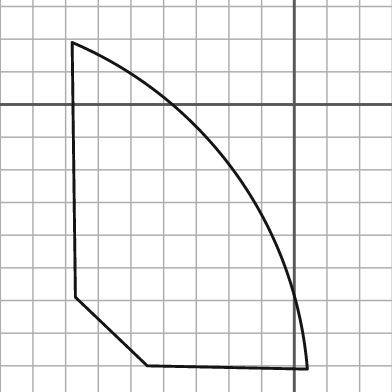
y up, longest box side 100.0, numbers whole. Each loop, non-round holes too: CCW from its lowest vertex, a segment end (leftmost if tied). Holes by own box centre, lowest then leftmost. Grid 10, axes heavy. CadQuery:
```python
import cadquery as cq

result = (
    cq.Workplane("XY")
    .moveTo(4.0, -81.0)
    .threePointArc((-18.0, -21.0), (-68.0, 19.0))
    .lineTo(-67.0, -59.0)
    .lineTo(-45.0, -80.0)
    .close()
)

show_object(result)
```